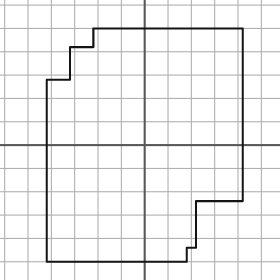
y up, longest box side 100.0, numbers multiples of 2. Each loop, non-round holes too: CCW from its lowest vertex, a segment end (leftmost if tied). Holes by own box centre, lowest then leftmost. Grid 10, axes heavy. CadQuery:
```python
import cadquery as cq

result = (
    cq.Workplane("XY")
    .moveTo(-42.0, -50.0)
    .lineTo(18.0, -50.0)
    .lineTo(18.0, -44.0)
    .lineTo(22.0, -44.0)
    .lineTo(22.0, -24.0)
    .lineTo(42.0, -24.0)
    .lineTo(42.0, 50.0)
    .lineTo(-22.0, 50.0)
    .lineTo(-22.0, 42.0)
    .lineTo(-32.0, 42.0)
    .lineTo(-32.0, 28.0)
    .lineTo(-42.0, 28.0)
    .close()
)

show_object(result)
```